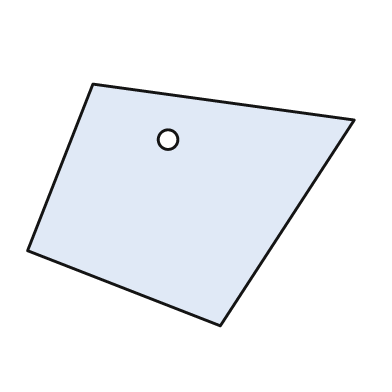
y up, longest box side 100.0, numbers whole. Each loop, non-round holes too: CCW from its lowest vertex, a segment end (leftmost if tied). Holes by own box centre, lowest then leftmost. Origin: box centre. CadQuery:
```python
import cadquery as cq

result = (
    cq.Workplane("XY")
    .moveTo(9.0, -37.0)
    .lineTo(50.0, 26.0)
    .lineTo(-30.0, 37.0)
    .lineTo(-50.0, -14.0)
    .close()
    .moveTo(-7.0, 20.0)
    .circle(3.0)
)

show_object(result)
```